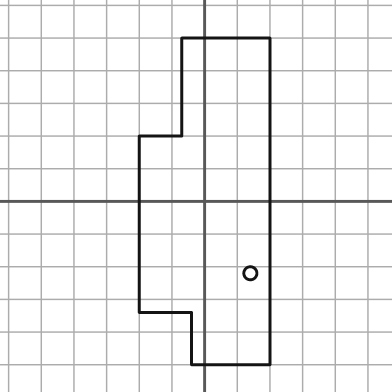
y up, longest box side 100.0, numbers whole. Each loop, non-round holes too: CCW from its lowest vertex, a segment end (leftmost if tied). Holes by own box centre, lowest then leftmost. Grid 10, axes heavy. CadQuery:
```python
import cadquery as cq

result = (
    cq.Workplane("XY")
    .moveTo(-4.0, -50.0)
    .lineTo(20.0, -50.0)
    .lineTo(20.0, 50.0)
    .lineTo(-7.0, 50.0)
    .lineTo(-7.0, 20.0)
    .lineTo(-20.0, 20.0)
    .lineTo(-20.0, -34.0)
    .lineTo(-4.0, -34.0)
    .close()
    .moveTo(14.0, -22.0)
    .circle(2.0)
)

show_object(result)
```